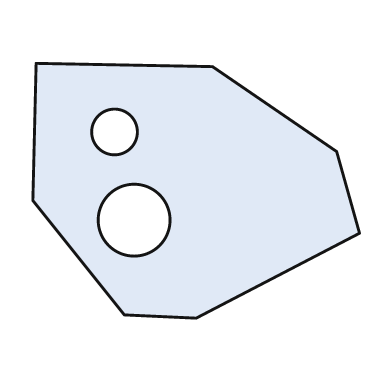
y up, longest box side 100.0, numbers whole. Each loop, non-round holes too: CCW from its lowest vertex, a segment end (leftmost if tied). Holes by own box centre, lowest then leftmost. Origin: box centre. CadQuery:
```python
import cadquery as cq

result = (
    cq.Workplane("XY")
    .moveTo(0.0, -39.0)
    .lineTo(50.0, -13.0)
    .lineTo(43.0, 12.0)
    .lineTo(5.0, 38.0)
    .lineTo(-49.0, 39.0)
    .lineTo(-50.0, -3.0)
    .lineTo(-22.0, -38.0)
    .close()
    .moveTo(-19.0, -9.0)
    .circle(11.0)
    .moveTo(-25.0, 18.0)
    .circle(7.0)
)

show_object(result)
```